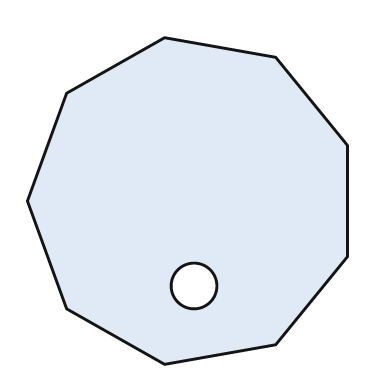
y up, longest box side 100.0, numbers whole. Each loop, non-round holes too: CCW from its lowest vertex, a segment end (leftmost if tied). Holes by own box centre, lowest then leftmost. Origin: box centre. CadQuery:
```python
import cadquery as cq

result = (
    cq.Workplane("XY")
    .moveTo(-7.0, -50.0)
    .lineTo(27.0, -44.0)
    .lineTo(49.0, -17.0)
    .lineTo(49.0, 17.0)
    .lineTo(27.0, 44.0)
    .lineTo(-7.0, 50.0)
    .lineTo(-37.0, 33.0)
    .lineTo(-49.0, 0.0)
    .lineTo(-37.0, -33.0)
    .close()
    .moveTo(2.0, -26.0)
    .circle(7.0)
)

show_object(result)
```